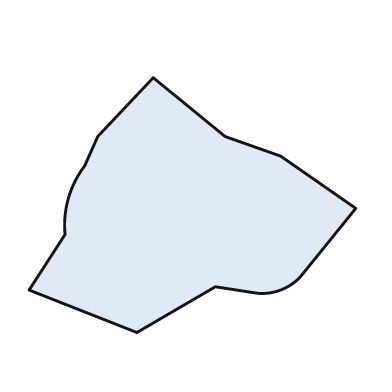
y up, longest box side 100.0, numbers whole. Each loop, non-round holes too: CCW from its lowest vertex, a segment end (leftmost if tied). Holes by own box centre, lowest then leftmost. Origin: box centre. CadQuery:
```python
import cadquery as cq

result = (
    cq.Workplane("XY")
    .moveTo(-17.0, -39.0)
    .lineTo(7.0, -25.0)
    .lineTo(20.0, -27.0)
    .threePointArc((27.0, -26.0), (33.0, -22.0))
    .lineTo(50.0, -1.0)
    .lineTo(27.0, 15.0)
    .lineTo(10.0, 21.0)
    .lineTo(-12.0, 39.0)
    .lineTo(-29.0, 21.0)
    .lineTo(-33.0, 12.0)
    .threePointArc((-38.0, 2.0), (-39.0, -9.0))
    .lineTo(-50.0, -26.0)
    .close()
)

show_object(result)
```